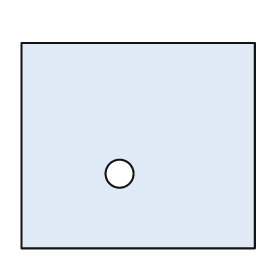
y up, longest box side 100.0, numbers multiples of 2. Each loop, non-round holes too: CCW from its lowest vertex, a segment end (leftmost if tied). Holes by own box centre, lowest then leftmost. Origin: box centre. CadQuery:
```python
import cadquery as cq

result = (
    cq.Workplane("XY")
    .moveTo(-50.0, -44.0)
    .lineTo(50.0, -44.0)
    .lineTo(50.0, 44.0)
    .lineTo(-50.0, 44.0)
    .close()
    .moveTo(-8.0, -12.0)
    .circle(6.0)
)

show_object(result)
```